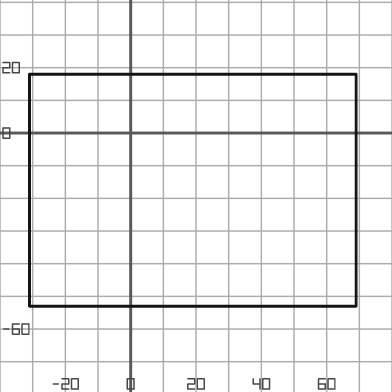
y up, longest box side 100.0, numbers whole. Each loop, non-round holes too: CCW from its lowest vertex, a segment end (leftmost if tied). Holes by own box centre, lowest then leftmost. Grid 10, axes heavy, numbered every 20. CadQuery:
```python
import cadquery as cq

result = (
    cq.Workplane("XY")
    .moveTo(-31.0, -53.0)
    .lineTo(69.0, -53.0)
    .lineTo(69.0, 18.0)
    .lineTo(-31.0, 18.0)
    .close()
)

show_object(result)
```